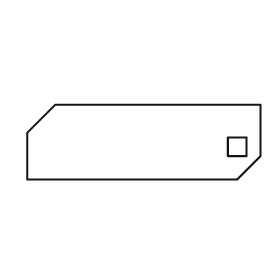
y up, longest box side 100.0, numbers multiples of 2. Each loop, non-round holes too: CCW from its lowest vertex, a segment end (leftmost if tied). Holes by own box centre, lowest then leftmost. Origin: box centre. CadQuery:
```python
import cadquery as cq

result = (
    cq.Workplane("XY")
    .moveTo(-50.0, -16.0)
    .lineTo(40.0, -16.0)
    .lineTo(50.0, -6.0)
    .lineTo(50.0, 16.0)
    .lineTo(-38.0, 16.0)
    .lineTo(-50.0, 4.0)
    .close()
    .moveTo(36.0, -6.0)
    .lineTo(44.0, -6.0)
    .lineTo(44.0, 2.0)
    .lineTo(36.0, 2.0)
    .close()
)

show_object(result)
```